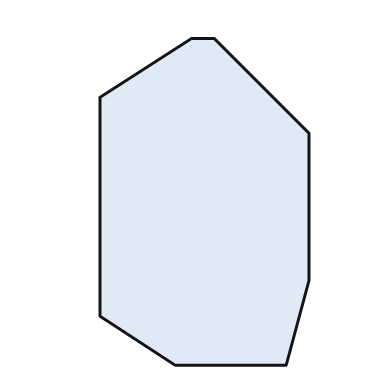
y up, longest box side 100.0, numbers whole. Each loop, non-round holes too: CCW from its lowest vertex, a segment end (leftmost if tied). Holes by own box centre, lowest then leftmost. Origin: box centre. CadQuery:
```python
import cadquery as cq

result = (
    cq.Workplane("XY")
    .moveTo(-9.0, -50.0)
    .lineTo(25.0, -50.0)
    .lineTo(32.0, -24.0)
    .lineTo(32.0, 21.0)
    .lineTo(3.0, 50.0)
    .lineTo(-4.0, 50.0)
    .lineTo(-32.0, 32.0)
    .lineTo(-32.0, -35.0)
    .close()
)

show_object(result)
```